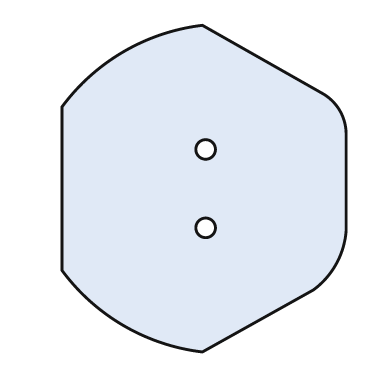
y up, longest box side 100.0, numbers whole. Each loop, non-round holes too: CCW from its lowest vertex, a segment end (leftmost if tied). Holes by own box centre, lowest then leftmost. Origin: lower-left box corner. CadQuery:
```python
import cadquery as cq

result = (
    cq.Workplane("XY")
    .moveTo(43.0, 0.0)
    .lineTo(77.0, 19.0)
    .threePointArc((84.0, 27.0), (87.0, 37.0))
    .lineTo(87.0, 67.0)
    .threePointArc((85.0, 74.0), (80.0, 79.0))
    .lineTo(43.0, 100.0)
    .threePointArc((19.0, 92.0), (0.0, 75.0))
    .lineTo(0.0, 25.0)
    .threePointArc((19.0, 8.0), (43.0, 0.0))
    .close()
    .moveTo(44.0, 38.0)
    .circle(3.0)
    .moveTo(44.0, 62.0)
    .circle(3.0)
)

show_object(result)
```